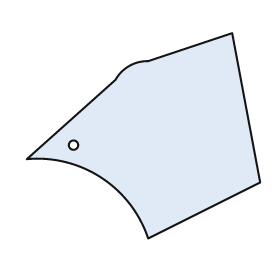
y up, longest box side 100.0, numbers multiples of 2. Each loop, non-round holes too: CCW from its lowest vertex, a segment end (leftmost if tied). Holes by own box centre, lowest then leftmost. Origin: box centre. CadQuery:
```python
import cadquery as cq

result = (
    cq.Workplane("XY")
    .moveTo(2.0, -44.0)
    .lineTo(50.0, -20.0)
    .lineTo(38.0, 44.0)
    .lineTo(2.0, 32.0)
    .threePointArc((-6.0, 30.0), (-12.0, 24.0))
    .lineTo(-50.0, -10.0)
    .threePointArc((-18.0, -18.0), (2.0, -44.0))
    .close()
    .moveTo(-30.0, -4.0)
    .circle(2.0)
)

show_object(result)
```